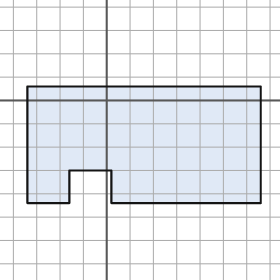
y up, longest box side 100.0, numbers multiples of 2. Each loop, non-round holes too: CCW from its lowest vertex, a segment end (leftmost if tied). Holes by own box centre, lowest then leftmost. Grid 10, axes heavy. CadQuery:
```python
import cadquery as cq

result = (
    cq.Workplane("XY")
    .moveTo(-34.0, -44.0)
    .lineTo(-16.0, -44.0)
    .lineTo(-16.0, -30.0)
    .lineTo(2.0, -30.0)
    .lineTo(2.0, -44.0)
    .lineTo(66.0, -44.0)
    .lineTo(66.0, 6.0)
    .lineTo(-34.0, 6.0)
    .close()
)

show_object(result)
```